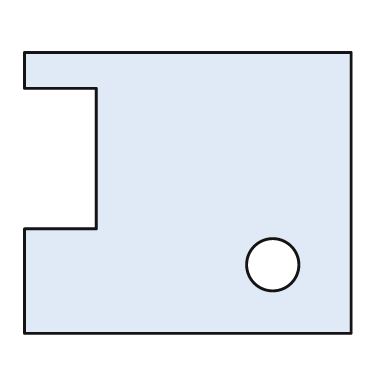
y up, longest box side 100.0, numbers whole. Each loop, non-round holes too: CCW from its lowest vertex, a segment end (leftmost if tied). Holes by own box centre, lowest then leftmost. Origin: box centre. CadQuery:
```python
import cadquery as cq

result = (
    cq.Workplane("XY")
    .moveTo(-50.0, -43.0)
    .lineTo(50.0, -43.0)
    .lineTo(50.0, 43.0)
    .lineTo(-50.0, 43.0)
    .lineTo(-50.0, 32.0)
    .lineTo(-28.0, 32.0)
    .lineTo(-28.0, -11.0)
    .lineTo(-50.0, -11.0)
    .close()
    .moveTo(26.0, -22.0)
    .circle(8.0)
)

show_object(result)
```